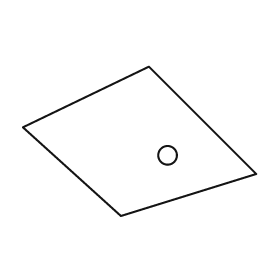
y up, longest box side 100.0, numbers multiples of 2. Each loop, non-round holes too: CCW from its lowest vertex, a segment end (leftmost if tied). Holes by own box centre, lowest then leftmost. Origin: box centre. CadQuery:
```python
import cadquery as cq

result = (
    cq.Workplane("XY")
    .moveTo(-8.0, -32.0)
    .lineTo(50.0, -14.0)
    .lineTo(4.0, 32.0)
    .lineTo(-50.0, 6.0)
    .close()
    .moveTo(12.0, -6.0)
    .circle(4.0)
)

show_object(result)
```